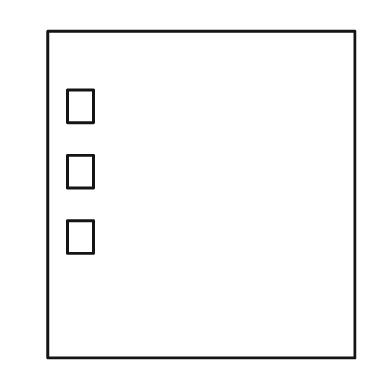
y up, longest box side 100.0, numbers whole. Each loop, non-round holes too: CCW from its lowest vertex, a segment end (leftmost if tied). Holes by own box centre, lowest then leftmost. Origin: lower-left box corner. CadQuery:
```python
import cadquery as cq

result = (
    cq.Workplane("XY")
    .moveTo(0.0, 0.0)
    .lineTo(94.0, 0.0)
    .lineTo(94.0, 100.0)
    .lineTo(0.0, 100.0)
    .close()
    .moveTo(6.0, 32.0)
    .lineTo(14.0, 32.0)
    .lineTo(14.0, 42.0)
    .lineTo(6.0, 42.0)
    .close()
    .moveTo(6.0, 52.0)
    .lineTo(14.0, 52.0)
    .lineTo(14.0, 62.0)
    .lineTo(6.0, 62.0)
    .close()
    .moveTo(6.0, 72.0)
    .lineTo(14.0, 72.0)
    .lineTo(14.0, 82.0)
    .lineTo(6.0, 82.0)
    .close()
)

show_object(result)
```